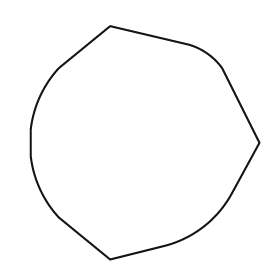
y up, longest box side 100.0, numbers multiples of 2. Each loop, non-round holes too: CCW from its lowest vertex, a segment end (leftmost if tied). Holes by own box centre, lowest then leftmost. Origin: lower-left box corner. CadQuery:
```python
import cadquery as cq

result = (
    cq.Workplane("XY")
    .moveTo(34.0, 0.0)
    .lineTo(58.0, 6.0)
    .threePointArc((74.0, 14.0), (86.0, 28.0))
    .lineTo(98.0, 50.0)
    .lineTo(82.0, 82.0)
    .threePointArc((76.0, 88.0), (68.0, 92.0))
    .lineTo(34.0, 100.0)
    .lineTo(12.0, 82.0)
    .threePointArc((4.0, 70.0), (0.0, 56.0))
    .lineTo(0.0, 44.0)
    .threePointArc((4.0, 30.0), (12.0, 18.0))
    .close()
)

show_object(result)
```